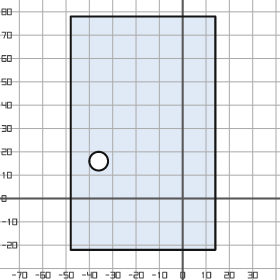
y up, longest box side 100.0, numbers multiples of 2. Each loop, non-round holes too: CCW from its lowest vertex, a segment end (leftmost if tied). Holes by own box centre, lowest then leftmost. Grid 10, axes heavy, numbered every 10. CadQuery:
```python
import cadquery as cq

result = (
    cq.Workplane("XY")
    .moveTo(-48.0, -22.0)
    .lineTo(14.0, -22.0)
    .lineTo(14.0, 78.0)
    .lineTo(-48.0, 78.0)
    .close()
    .moveTo(-36.0, 16.0)
    .circle(4.0)
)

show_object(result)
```